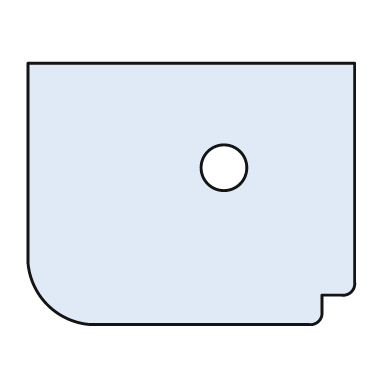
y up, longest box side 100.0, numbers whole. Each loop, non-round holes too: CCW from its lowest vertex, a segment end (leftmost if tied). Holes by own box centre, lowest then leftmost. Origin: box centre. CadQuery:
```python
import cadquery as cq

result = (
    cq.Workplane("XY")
    .moveTo(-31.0, -40.0)
    .lineTo(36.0, -40.0)
    .threePointArc((39.0, -39.0), (40.0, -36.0))
    .lineTo(40.0, -31.0)
    .lineTo(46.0, -31.0)
    .threePointArc((49.0, -30.0), (50.0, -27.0))
    .lineTo(50.0, 40.0)
    .lineTo(-50.0, 40.0)
    .lineTo(-50.0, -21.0)
    .threePointArc((-44.0, -34.0), (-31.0, -40.0))
    .close()
    .moveTo(10.0, 8.0)
    .circle(7.0)
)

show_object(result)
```